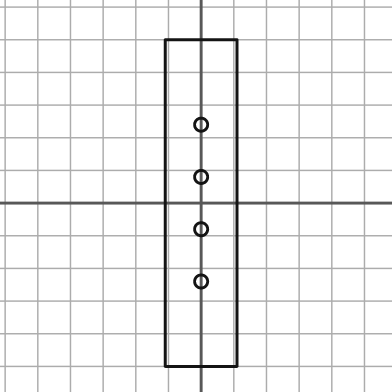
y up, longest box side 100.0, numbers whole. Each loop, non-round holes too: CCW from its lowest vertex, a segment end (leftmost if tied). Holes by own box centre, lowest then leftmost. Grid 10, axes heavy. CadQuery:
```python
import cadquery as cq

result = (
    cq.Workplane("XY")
    .moveTo(-11.0, -50.0)
    .lineTo(11.0, -50.0)
    .lineTo(11.0, 50.0)
    .lineTo(-11.0, 50.0)
    .close()
    .moveTo(0.0, -24.0)
    .circle(2.0)
    .moveTo(0.0, -8.0)
    .circle(2.0)
    .moveTo(0.0, 8.0)
    .circle(2.0)
    .moveTo(0.0, 24.0)
    .circle(2.0)
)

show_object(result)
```